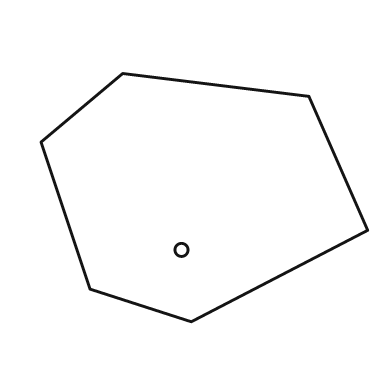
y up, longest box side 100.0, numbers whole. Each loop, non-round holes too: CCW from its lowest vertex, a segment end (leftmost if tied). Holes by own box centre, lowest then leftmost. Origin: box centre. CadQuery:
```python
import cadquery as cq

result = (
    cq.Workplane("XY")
    .moveTo(-4.0, -38.0)
    .lineTo(50.0, -10.0)
    .lineTo(32.0, 31.0)
    .lineTo(-25.0, 38.0)
    .lineTo(-50.0, 17.0)
    .lineTo(-35.0, -28.0)
    .close()
    .moveTo(-7.0, -16.0)
    .circle(2.0)
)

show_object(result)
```